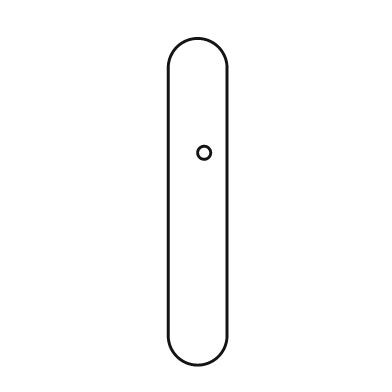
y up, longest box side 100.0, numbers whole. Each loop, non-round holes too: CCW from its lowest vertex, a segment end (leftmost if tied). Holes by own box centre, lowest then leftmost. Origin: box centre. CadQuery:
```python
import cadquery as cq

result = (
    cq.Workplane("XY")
    .moveTo(-9.0, -41.0)
    .threePointArc((0.0, -50.0), (9.0, -41.0))
    .lineTo(9.0, 41.0)
    .threePointArc((0.0, 50.0), (-9.0, 41.0))
    .close()
    .moveTo(2.0, 15.0)
    .circle(2.0)
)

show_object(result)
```